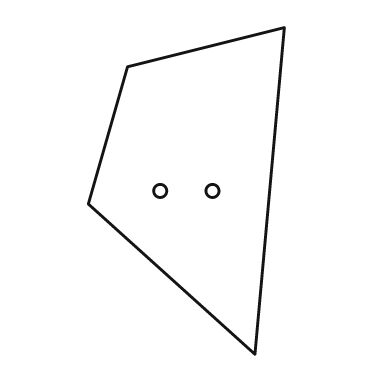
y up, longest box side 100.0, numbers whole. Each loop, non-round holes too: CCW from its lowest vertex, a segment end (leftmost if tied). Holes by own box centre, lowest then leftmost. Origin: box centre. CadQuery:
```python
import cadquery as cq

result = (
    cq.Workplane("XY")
    .moveTo(21.0, -50.0)
    .lineTo(30.0, 50.0)
    .lineTo(-18.0, 38.0)
    .lineTo(-30.0, -4.0)
    .close()
    .moveTo(-8.0, 0.0)
    .circle(2.0)
    .moveTo(8.0, 0.0)
    .circle(2.0)
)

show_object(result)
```